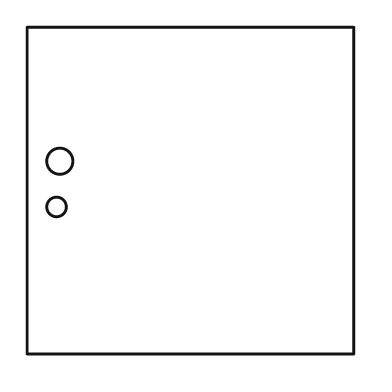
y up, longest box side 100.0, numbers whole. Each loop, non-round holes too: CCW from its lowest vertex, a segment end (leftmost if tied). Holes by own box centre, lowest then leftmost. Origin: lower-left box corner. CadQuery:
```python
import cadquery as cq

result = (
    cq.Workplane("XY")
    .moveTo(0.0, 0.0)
    .lineTo(100.0, 0.0)
    .lineTo(100.0, 100.0)
    .lineTo(0.0, 100.0)
    .close()
    .moveTo(9.0, 45.0)
    .circle(3.0)
    .moveTo(10.0, 59.0)
    .circle(4.0)
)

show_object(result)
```